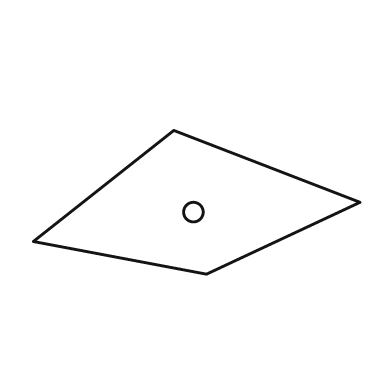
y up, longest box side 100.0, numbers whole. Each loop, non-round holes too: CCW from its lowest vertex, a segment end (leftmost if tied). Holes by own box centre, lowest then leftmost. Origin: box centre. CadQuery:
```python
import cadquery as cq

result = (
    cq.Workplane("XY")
    .moveTo(3.0, -22.0)
    .lineTo(50.0, 0.0)
    .lineTo(-7.0, 22.0)
    .lineTo(-50.0, -12.0)
    .close()
    .moveTo(-1.0, -3.0)
    .circle(3.0)
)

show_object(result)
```